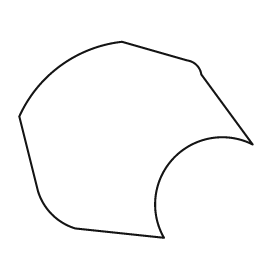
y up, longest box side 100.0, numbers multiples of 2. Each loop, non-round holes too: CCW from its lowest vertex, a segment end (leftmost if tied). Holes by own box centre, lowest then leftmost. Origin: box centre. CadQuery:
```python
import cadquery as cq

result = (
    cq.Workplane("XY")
    .moveTo(12.0, -42.0)
    .threePointArc((16.0, -8.0), (50.0, -2.0))
    .lineTo(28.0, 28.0)
    .threePointArc((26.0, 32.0), (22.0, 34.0))
    .lineTo(-6.0, 42.0)
    .threePointArc((-32.0, 32.0), (-50.0, 10.0))
    .lineTo(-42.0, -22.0)
    .threePointArc((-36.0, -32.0), (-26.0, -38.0))
    .close()
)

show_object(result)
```